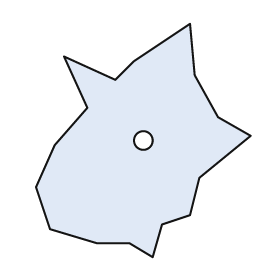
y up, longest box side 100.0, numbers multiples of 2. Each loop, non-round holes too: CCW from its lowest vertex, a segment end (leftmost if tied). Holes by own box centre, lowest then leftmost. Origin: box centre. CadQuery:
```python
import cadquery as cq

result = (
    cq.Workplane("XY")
    .moveTo(4.0, -50.0)
    .lineTo(8.0, -36.0)
    .lineTo(20.0, -32.0)
    .lineTo(24.0, -16.0)
    .lineTo(46.0, 2.0)
    .lineTo(32.0, 10.0)
    .lineTo(22.0, 28.0)
    .lineTo(20.0, 50.0)
    .lineTo(-4.0, 34.0)
    .lineTo(-12.0, 26.0)
    .lineTo(-34.0, 36.0)
    .lineTo(-24.0, 14.0)
    .lineTo(-38.0, -2.0)
    .lineTo(-46.0, -20.0)
    .lineTo(-40.0, -38.0)
    .lineTo(-20.0, -44.0)
    .lineTo(-6.0, -44.0)
    .close()
    .moveTo(0.0, 0.0)
    .circle(4.0)
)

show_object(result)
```